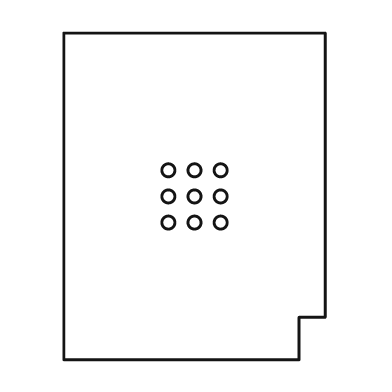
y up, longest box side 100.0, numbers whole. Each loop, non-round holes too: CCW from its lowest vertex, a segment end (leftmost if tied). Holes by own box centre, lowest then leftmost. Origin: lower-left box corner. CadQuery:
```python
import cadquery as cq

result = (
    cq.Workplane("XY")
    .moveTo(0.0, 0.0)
    .lineTo(72.0, 0.0)
    .lineTo(72.0, 13.0)
    .lineTo(80.0, 13.0)
    .lineTo(80.0, 100.0)
    .lineTo(0.0, 100.0)
    .close()
    .moveTo(32.0, 42.0)
    .circle(2.0)
    .moveTo(40.0, 42.0)
    .circle(2.0)
    .moveTo(48.0, 42.0)
    .circle(2.0)
    .moveTo(32.0, 50.0)
    .circle(2.0)
    .moveTo(40.0, 50.0)
    .circle(2.0)
    .moveTo(48.0, 50.0)
    .circle(2.0)
    .moveTo(32.0, 58.0)
    .circle(2.0)
    .moveTo(40.0, 58.0)
    .circle(2.0)
    .moveTo(48.0, 58.0)
    .circle(2.0)
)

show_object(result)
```